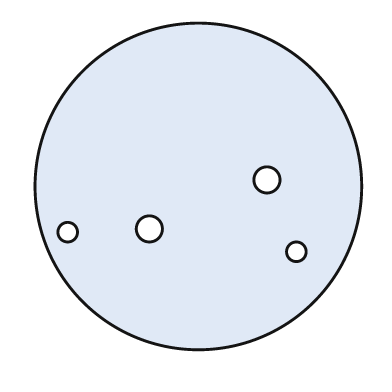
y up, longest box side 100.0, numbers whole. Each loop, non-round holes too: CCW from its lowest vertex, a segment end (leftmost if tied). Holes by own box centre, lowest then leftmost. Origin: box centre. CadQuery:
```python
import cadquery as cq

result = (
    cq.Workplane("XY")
    .moveTo(0.0, 0.0)
    .circle(50.0)
    .moveTo(30.0, -20.0)
    .circle(3.0)
    .moveTo(-40.0, -14.0)
    .circle(3.0)
    .moveTo(-15.0, -13.0)
    .circle(4.0)
    .moveTo(21.0, 2.0)
    .circle(4.0)
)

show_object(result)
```